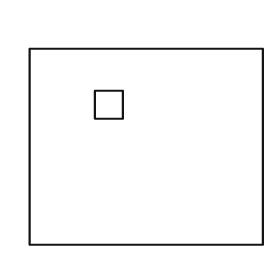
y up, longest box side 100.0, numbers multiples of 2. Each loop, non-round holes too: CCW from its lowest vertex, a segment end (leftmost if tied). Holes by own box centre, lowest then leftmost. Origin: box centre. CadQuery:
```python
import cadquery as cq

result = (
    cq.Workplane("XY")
    .moveTo(-50.0, -42.0)
    .lineTo(50.0, -42.0)
    .lineTo(50.0, 42.0)
    .lineTo(-50.0, 42.0)
    .close()
    .moveTo(-22.0, 12.0)
    .lineTo(-10.0, 12.0)
    .lineTo(-10.0, 24.0)
    .lineTo(-22.0, 24.0)
    .close()
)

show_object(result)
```